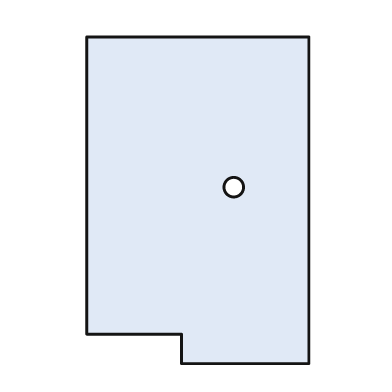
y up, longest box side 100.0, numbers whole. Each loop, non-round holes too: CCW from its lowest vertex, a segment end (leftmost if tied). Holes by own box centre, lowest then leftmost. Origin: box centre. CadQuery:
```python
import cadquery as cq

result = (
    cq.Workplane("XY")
    .moveTo(-5.0, -50.0)
    .lineTo(34.0, -50.0)
    .lineTo(34.0, 50.0)
    .lineTo(-34.0, 50.0)
    .lineTo(-34.0, -41.0)
    .lineTo(-5.0, -41.0)
    .close()
    .moveTo(11.0, 4.0)
    .circle(3.0)
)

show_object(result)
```